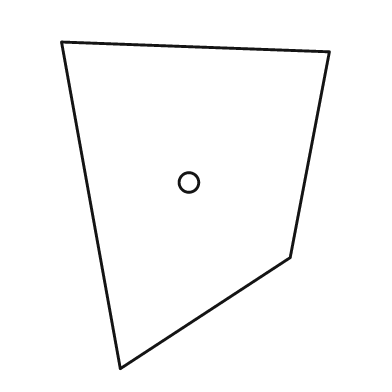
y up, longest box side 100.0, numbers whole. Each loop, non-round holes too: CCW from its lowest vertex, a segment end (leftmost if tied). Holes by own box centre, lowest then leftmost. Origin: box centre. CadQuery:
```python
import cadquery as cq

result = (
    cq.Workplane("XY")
    .moveTo(-23.0, -50.0)
    .lineTo(29.0, -16.0)
    .lineTo(41.0, 47.0)
    .lineTo(-41.0, 50.0)
    .close()
    .moveTo(-2.0, 7.0)
    .circle(3.0)
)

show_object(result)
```